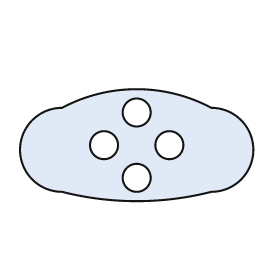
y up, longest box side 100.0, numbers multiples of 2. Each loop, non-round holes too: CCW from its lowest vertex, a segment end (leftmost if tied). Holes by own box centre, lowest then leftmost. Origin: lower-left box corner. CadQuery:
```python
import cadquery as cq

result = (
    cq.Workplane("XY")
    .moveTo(18.0, 4.0)
    .threePointArc((50.0, 0.0), (82.0, 4.0))
    .threePointArc((100.0, 22.0), (82.0, 40.0))
    .threePointArc((50.0, 48.0), (18.0, 40.0))
    .threePointArc((0.0, 22.0), (18.0, 4.0))
    .close()
    .moveTo(50.0, 10.0)
    .circle(6.0)
    .moveTo(36.0, 24.0)
    .circle(6.0)
    .moveTo(64.0, 24.0)
    .circle(6.0)
    .moveTo(50.0, 38.0)
    .circle(6.0)
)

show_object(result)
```